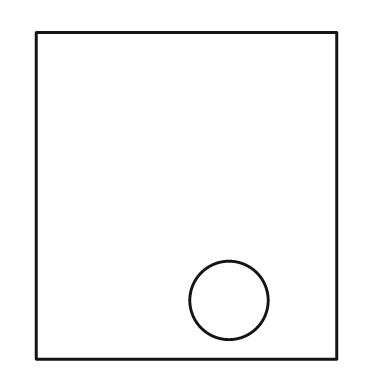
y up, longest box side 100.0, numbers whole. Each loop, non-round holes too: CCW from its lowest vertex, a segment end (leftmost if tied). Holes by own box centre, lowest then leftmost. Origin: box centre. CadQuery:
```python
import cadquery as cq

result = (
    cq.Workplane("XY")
    .moveTo(-46.0, -50.0)
    .lineTo(46.0, -50.0)
    .lineTo(46.0, 50.0)
    .lineTo(-46.0, 50.0)
    .close()
    .moveTo(13.0, -32.0)
    .circle(12.0)
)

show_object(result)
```